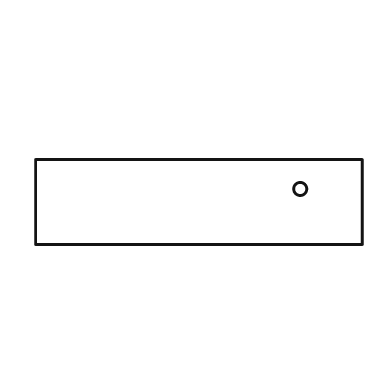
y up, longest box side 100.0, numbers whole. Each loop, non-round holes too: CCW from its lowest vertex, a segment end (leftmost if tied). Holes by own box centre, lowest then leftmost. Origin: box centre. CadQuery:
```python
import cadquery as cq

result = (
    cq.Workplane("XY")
    .moveTo(-50.0, -13.0)
    .lineTo(50.0, -13.0)
    .lineTo(50.0, 13.0)
    .lineTo(-50.0, 13.0)
    .close()
    .moveTo(31.0, 4.0)
    .circle(2.0)
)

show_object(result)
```